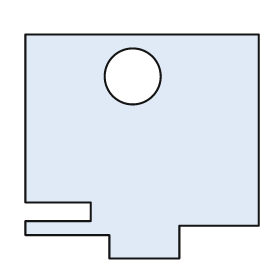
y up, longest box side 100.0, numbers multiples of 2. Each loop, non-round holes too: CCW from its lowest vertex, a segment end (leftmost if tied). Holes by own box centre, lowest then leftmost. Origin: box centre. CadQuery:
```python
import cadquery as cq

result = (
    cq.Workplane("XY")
    .moveTo(-14.0, -48.0)
    .lineTo(16.0, -48.0)
    .lineTo(16.0, -34.0)
    .lineTo(50.0, -34.0)
    .lineTo(50.0, 48.0)
    .lineTo(-50.0, 48.0)
    .lineTo(-50.0, -24.0)
    .lineTo(-22.0, -24.0)
    .lineTo(-22.0, -32.0)
    .lineTo(-50.0, -32.0)
    .lineTo(-50.0, -38.0)
    .lineTo(-14.0, -38.0)
    .close()
    .moveTo(-4.0, 30.0)
    .circle(12.0)
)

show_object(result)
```